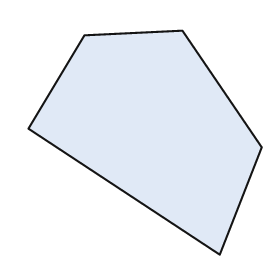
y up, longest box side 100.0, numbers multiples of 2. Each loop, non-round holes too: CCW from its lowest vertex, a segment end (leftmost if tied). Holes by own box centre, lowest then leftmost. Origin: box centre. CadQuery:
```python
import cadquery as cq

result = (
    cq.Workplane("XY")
    .moveTo(32.0, -48.0)
    .lineTo(50.0, -2.0)
    .lineTo(16.0, 48.0)
    .lineTo(-26.0, 46.0)
    .lineTo(-50.0, 6.0)
    .close()
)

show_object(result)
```